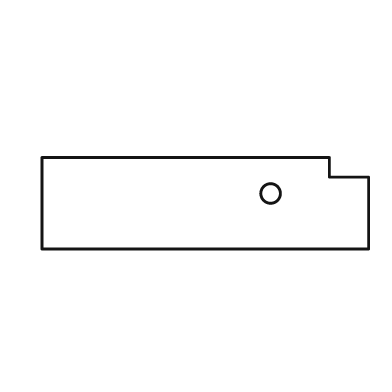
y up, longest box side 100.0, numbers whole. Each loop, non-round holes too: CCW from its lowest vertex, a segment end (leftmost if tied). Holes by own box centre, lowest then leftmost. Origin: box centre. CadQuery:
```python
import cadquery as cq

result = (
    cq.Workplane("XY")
    .moveTo(-50.0, -14.0)
    .lineTo(50.0, -14.0)
    .lineTo(50.0, 8.0)
    .lineTo(38.0, 8.0)
    .lineTo(38.0, 14.0)
    .lineTo(-50.0, 14.0)
    .close()
    .moveTo(20.0, 3.0)
    .circle(3.0)
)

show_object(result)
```